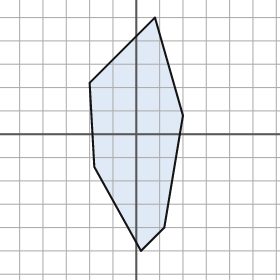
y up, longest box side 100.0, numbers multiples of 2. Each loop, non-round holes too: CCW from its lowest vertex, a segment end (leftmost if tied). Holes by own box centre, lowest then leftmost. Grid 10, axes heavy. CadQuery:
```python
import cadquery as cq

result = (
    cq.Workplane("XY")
    .moveTo(2.0, -50.0)
    .lineTo(12.0, -40.0)
    .lineTo(20.0, 8.0)
    .lineTo(8.0, 50.0)
    .lineTo(-20.0, 22.0)
    .lineTo(-18.0, -14.0)
    .close()
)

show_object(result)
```